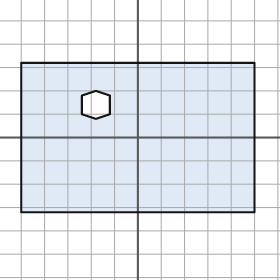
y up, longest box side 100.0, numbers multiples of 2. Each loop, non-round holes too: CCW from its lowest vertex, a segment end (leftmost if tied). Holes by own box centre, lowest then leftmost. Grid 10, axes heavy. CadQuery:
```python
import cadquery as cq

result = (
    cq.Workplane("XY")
    .moveTo(-50.0, -32.0)
    .lineTo(50.0, -32.0)
    .lineTo(50.0, 32.0)
    .lineTo(-50.0, 32.0)
    .close()
    .moveTo(-18.0, 8.0)
    .lineTo(-12.0, 10.0)
    .lineTo(-12.0, 18.0)
    .lineTo(-18.0, 20.0)
    .lineTo(-24.0, 18.0)
    .lineTo(-24.0, 10.0)
    .close()
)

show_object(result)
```